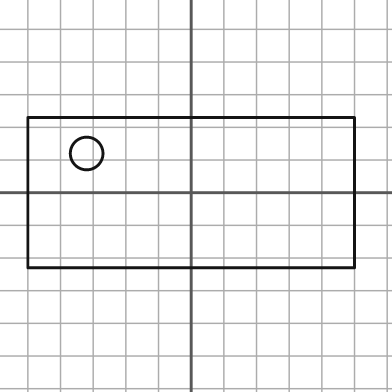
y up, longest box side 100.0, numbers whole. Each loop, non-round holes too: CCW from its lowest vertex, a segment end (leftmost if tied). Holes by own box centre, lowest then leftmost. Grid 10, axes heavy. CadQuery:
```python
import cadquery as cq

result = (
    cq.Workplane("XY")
    .moveTo(-50.0, -23.0)
    .lineTo(50.0, -23.0)
    .lineTo(50.0, 23.0)
    .lineTo(-50.0, 23.0)
    .close()
    .moveTo(-32.0, 12.0)
    .circle(5.0)
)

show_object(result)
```